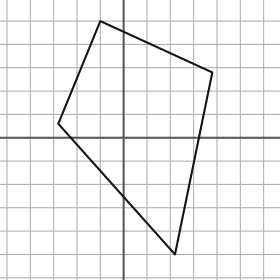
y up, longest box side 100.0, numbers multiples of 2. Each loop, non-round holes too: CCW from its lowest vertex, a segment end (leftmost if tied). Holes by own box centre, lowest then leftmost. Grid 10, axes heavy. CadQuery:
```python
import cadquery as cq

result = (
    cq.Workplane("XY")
    .moveTo(22.0, -50.0)
    .lineTo(38.0, 28.0)
    .lineTo(-10.0, 50.0)
    .lineTo(-28.0, 6.0)
    .close()
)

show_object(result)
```